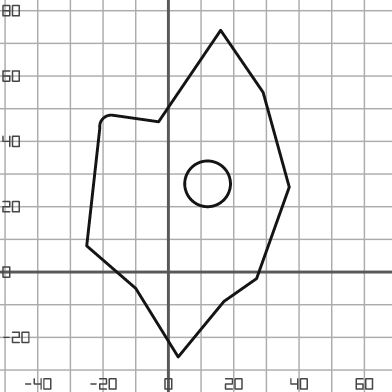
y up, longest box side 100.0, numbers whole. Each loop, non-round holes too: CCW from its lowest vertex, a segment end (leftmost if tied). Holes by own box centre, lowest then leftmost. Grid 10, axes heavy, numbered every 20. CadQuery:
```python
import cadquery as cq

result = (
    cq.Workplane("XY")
    .moveTo(3.0, -26.0)
    .lineTo(17.0, -9.0)
    .lineTo(27.0, -2.0)
    .lineTo(37.0, 26.0)
    .lineTo(29.0, 55.0)
    .lineTo(16.0, 74.0)
    .lineTo(-3.0, 46.0)
    .lineTo(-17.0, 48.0)
    .threePointArc((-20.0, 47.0), (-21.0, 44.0))
    .lineTo(-25.0, 8.0)
    .lineTo(-10.0, -5.0)
    .close()
    .moveTo(12.0, 27.0)
    .circle(7.0)
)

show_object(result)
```